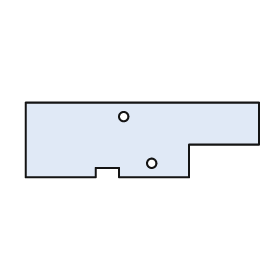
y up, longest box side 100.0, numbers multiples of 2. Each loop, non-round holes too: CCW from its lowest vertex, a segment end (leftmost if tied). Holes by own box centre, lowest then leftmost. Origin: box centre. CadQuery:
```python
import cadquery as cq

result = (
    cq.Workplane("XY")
    .moveTo(-50.0, -16.0)
    .lineTo(-20.0, -16.0)
    .lineTo(-20.0, -12.0)
    .lineTo(-10.0, -12.0)
    .lineTo(-10.0, -16.0)
    .lineTo(20.0, -16.0)
    .lineTo(20.0, -2.0)
    .lineTo(50.0, -2.0)
    .lineTo(50.0, 16.0)
    .lineTo(-50.0, 16.0)
    .close()
    .moveTo(4.0, -10.0)
    .circle(2.0)
    .moveTo(-8.0, 10.0)
    .circle(2.0)
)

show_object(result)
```